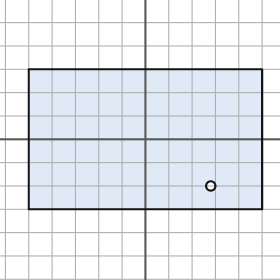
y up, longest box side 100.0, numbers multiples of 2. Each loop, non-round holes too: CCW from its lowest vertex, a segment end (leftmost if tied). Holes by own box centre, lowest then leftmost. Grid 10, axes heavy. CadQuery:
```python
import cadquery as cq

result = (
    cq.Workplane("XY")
    .moveTo(-50.0, -30.0)
    .lineTo(50.0, -30.0)
    .lineTo(50.0, 30.0)
    .lineTo(-50.0, 30.0)
    .close()
    .moveTo(28.0, -20.0)
    .circle(2.0)
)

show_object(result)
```